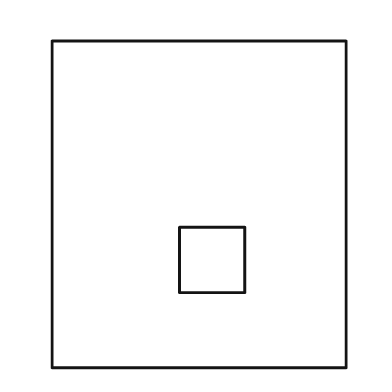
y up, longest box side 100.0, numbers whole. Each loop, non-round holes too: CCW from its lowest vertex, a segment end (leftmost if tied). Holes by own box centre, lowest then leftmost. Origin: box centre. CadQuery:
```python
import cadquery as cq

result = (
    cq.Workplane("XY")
    .moveTo(-45.0, -50.0)
    .lineTo(45.0, -50.0)
    .lineTo(45.0, 50.0)
    .lineTo(-45.0, 50.0)
    .close()
    .moveTo(-6.0, -27.0)
    .lineTo(14.0, -27.0)
    .lineTo(14.0, -7.0)
    .lineTo(-6.0, -7.0)
    .close()
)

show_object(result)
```